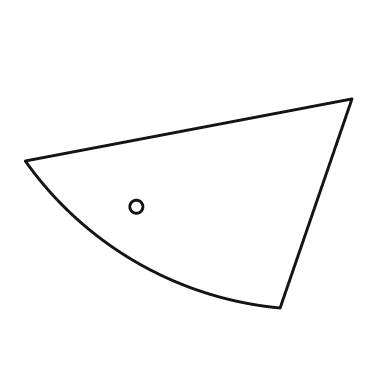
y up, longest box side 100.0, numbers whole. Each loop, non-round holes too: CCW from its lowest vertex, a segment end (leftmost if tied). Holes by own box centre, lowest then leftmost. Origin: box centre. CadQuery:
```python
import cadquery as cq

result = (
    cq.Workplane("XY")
    .moveTo(28.0, -32.0)
    .lineTo(50.0, 32.0)
    .lineTo(-50.0, 13.0)
    .threePointArc((-16.0, -18.0), (28.0, -32.0))
    .close()
    .moveTo(-16.0, -1.0)
    .circle(2.0)
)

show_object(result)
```